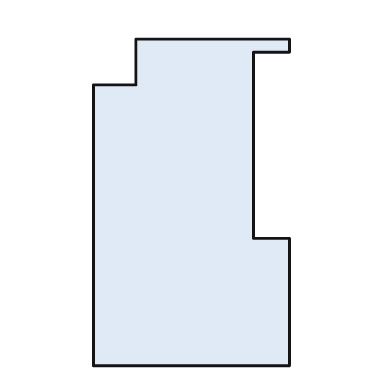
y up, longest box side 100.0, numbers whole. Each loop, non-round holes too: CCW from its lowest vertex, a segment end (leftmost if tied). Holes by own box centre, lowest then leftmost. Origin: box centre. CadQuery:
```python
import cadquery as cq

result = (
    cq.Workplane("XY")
    .moveTo(-30.0, -50.0)
    .lineTo(30.0, -50.0)
    .lineTo(30.0, -11.0)
    .lineTo(19.0, -11.0)
    .lineTo(19.0, 46.0)
    .lineTo(30.0, 46.0)
    .lineTo(30.0, 50.0)
    .lineTo(-17.0, 50.0)
    .lineTo(-17.0, 36.0)
    .lineTo(-30.0, 36.0)
    .close()
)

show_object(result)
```